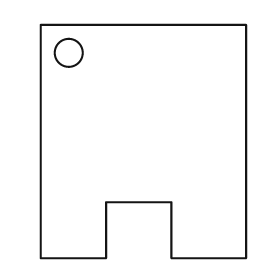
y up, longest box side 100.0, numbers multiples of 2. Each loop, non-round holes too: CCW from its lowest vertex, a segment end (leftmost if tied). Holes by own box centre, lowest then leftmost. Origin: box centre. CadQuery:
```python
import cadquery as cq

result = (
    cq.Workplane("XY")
    .moveTo(-44.0, -50.0)
    .lineTo(-16.0, -50.0)
    .lineTo(-16.0, -26.0)
    .lineTo(12.0, -26.0)
    .lineTo(12.0, -50.0)
    .lineTo(44.0, -50.0)
    .lineTo(44.0, 50.0)
    .lineTo(-44.0, 50.0)
    .close()
    .moveTo(-32.0, 38.0)
    .circle(6.0)
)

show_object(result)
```